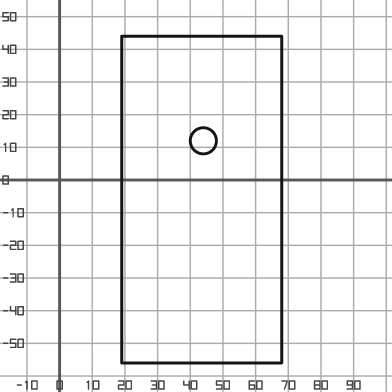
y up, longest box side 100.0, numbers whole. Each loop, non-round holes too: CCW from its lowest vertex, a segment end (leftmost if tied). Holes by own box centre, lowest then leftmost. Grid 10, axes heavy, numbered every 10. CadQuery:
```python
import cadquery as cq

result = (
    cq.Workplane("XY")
    .moveTo(19.0, -56.0)
    .lineTo(68.0, -56.0)
    .lineTo(68.0, 44.0)
    .lineTo(19.0, 44.0)
    .close()
    .moveTo(44.0, 12.0)
    .circle(4.0)
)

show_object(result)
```